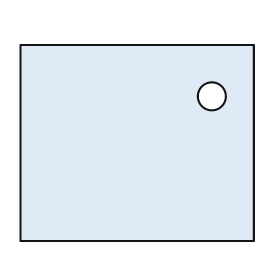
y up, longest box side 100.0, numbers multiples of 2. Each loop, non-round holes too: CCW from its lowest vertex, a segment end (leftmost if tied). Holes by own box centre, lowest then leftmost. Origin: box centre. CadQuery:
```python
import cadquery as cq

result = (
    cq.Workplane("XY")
    .moveTo(-50.0, -42.0)
    .lineTo(50.0, -42.0)
    .lineTo(50.0, 42.0)
    .lineTo(-50.0, 42.0)
    .close()
    .moveTo(32.0, 20.0)
    .circle(6.0)
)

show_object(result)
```